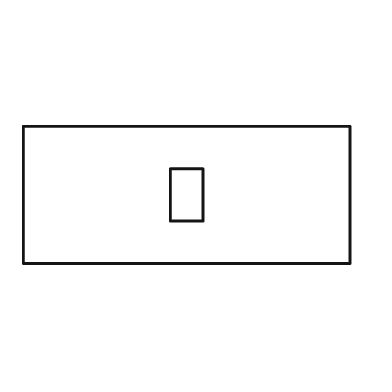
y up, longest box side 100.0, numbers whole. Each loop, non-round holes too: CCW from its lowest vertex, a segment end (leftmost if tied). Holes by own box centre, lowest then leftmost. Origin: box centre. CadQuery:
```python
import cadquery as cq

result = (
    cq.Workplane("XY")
    .moveTo(-50.0, -21.0)
    .lineTo(50.0, -21.0)
    .lineTo(50.0, 21.0)
    .lineTo(-50.0, 21.0)
    .close()
    .moveTo(-5.0, -8.0)
    .lineTo(5.0, -8.0)
    .lineTo(5.0, 8.0)
    .lineTo(-5.0, 8.0)
    .close()
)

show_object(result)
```